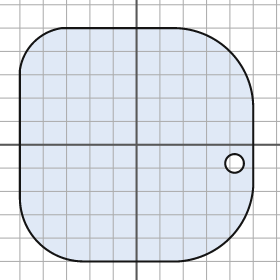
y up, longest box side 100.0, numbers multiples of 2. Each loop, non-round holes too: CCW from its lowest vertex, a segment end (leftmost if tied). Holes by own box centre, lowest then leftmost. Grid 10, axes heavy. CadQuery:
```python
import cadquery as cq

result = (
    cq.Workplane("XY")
    .moveTo(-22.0, -50.0)
    .lineTo(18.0, -50.0)
    .threePointArc((40.0, -40.0), (50.0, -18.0))
    .lineTo(50.0, 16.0)
    .threePointArc((40.0, 40.0), (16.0, 50.0))
    .lineTo(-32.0, 50.0)
    .threePointArc((-44.0, 44.0), (-50.0, 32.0))
    .lineTo(-50.0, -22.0)
    .threePointArc((-42.0, -42.0), (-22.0, -50.0))
    .close()
    .moveTo(42.0, -8.0)
    .circle(4.0)
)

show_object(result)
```